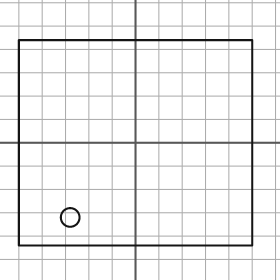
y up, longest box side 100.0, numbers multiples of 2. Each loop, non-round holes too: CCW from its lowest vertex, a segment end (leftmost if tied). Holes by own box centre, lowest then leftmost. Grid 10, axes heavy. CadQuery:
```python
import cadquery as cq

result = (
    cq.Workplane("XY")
    .moveTo(-50.0, -44.0)
    .lineTo(50.0, -44.0)
    .lineTo(50.0, 44.0)
    .lineTo(-50.0, 44.0)
    .close()
    .moveTo(-28.0, -32.0)
    .circle(4.0)
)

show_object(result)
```